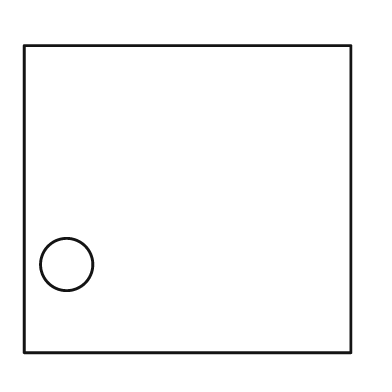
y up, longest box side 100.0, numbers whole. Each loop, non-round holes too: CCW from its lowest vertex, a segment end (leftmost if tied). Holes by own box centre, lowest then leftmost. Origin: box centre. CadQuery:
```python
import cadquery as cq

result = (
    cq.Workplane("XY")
    .moveTo(-50.0, -47.0)
    .lineTo(50.0, -47.0)
    .lineTo(50.0, 47.0)
    .lineTo(-50.0, 47.0)
    .close()
    .moveTo(-37.0, -20.0)
    .circle(8.0)
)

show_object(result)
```